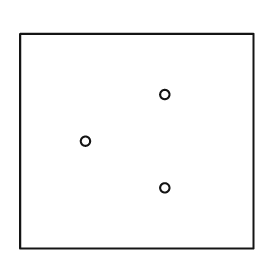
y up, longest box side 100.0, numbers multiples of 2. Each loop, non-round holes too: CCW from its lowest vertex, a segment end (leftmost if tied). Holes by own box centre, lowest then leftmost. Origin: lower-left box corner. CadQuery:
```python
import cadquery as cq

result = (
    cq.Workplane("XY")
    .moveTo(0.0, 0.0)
    .lineTo(100.0, 0.0)
    .lineTo(100.0, 92.0)
    .lineTo(0.0, 92.0)
    .close()
    .moveTo(62.0, 26.0)
    .circle(2.0)
    .moveTo(28.0, 46.0)
    .circle(2.0)
    .moveTo(62.0, 66.0)
    .circle(2.0)
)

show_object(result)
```